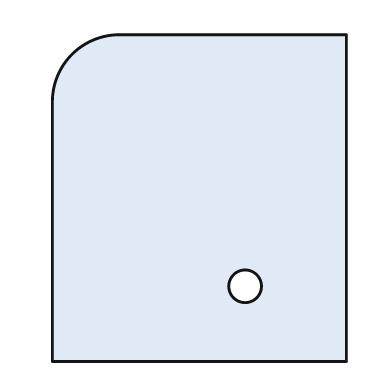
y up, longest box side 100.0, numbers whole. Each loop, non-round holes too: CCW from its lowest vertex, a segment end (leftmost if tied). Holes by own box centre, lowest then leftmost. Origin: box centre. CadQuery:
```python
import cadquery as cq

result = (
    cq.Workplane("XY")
    .moveTo(-45.0, -50.0)
    .lineTo(45.0, -50.0)
    .lineTo(45.0, 50.0)
    .lineTo(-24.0, 50.0)
    .threePointArc((-39.0, 44.0), (-45.0, 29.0))
    .close()
    .moveTo(14.0, -27.0)
    .circle(5.0)
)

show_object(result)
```